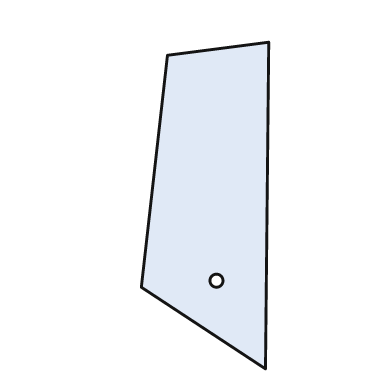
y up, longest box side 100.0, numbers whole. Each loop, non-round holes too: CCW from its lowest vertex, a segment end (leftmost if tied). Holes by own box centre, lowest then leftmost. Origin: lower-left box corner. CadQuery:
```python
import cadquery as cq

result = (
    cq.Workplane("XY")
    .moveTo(38.0, 0.0)
    .lineTo(39.0, 100.0)
    .lineTo(8.0, 96.0)
    .lineTo(0.0, 25.0)
    .close()
    .moveTo(23.0, 27.0)
    .circle(2.0)
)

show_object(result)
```